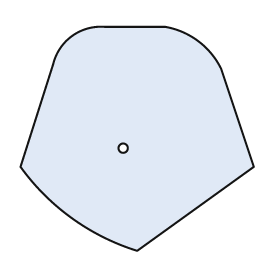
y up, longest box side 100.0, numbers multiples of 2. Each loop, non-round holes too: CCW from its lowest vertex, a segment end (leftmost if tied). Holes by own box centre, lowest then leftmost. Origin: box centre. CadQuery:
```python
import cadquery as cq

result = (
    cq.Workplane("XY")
    .moveTo(0.0, -48.0)
    .lineTo(50.0, -12.0)
    .lineTo(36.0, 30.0)
    .threePointArc((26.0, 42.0), (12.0, 48.0))
    .lineTo(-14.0, 48.0)
    .threePointArc((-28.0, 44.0), (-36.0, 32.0))
    .lineTo(-50.0, -12.0)
    .threePointArc((-28.0, -34.0), (0.0, -48.0))
    .close()
    .moveTo(-6.0, -4.0)
    .circle(2.0)
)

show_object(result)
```